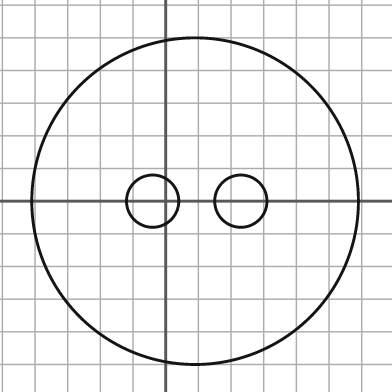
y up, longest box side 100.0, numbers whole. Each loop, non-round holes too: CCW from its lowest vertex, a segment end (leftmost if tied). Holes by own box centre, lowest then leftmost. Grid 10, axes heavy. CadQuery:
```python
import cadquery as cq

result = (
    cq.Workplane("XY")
    .moveTo(9.0, 0.0)
    .circle(50.0)
    .moveTo(-4.0, 0.0)
    .circle(8.0)
    .moveTo(23.0, 0.0)
    .circle(8.0)
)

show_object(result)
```